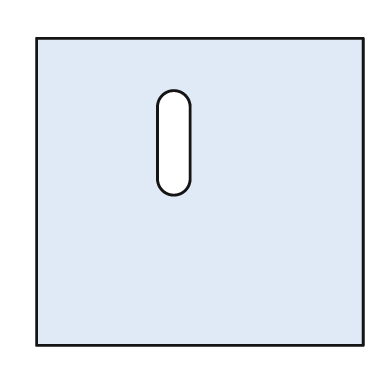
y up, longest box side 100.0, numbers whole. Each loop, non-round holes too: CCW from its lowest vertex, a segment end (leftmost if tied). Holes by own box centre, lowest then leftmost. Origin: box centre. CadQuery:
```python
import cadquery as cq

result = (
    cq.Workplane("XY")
    .moveTo(-50.0, -47.0)
    .lineTo(50.0, -47.0)
    .lineTo(50.0, 47.0)
    .lineTo(-50.0, 47.0)
    .close()
    .moveTo(-13.0, 4.0)
    .threePointArc((-8.0, -1.0), (-3.0, 4.0))
    .lineTo(-3.0, 26.0)
    .threePointArc((-8.0, 31.0), (-13.0, 26.0))
    .close()
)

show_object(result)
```